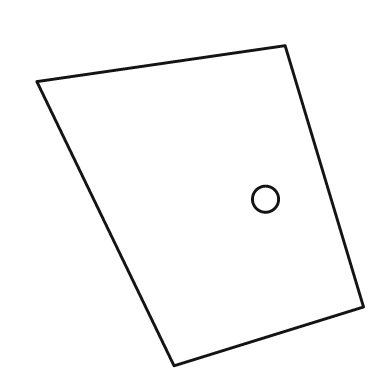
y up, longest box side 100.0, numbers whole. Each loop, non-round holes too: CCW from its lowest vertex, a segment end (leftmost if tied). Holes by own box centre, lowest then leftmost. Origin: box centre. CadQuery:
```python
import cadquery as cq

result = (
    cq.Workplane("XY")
    .moveTo(-8.0, -49.0)
    .lineTo(50.0, -31.0)
    .lineTo(26.0, 49.0)
    .lineTo(-50.0, 38.0)
    .close()
    .moveTo(20.0, 2.0)
    .circle(4.0)
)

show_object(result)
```